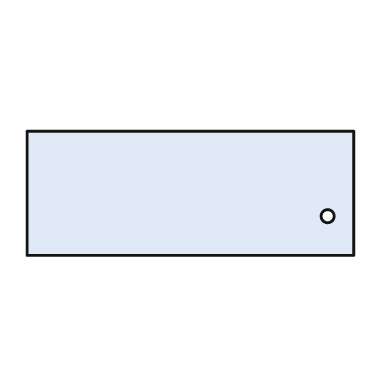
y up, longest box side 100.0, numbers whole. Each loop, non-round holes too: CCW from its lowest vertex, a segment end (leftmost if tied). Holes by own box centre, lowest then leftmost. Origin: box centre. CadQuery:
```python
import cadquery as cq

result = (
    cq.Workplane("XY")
    .moveTo(-50.0, -19.0)
    .lineTo(50.0, -19.0)
    .lineTo(50.0, 19.0)
    .lineTo(-50.0, 19.0)
    .close()
    .moveTo(42.0, -7.0)
    .circle(2.0)
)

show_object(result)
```